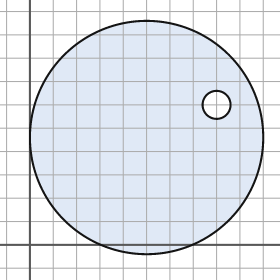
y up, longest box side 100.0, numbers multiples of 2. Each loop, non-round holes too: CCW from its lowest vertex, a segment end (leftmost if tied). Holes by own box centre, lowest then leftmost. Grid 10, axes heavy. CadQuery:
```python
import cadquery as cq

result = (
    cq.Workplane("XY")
    .moveTo(50.0, 46.0)
    .circle(50.0)
    .moveTo(80.0, 60.0)
    .circle(6.0)
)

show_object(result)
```